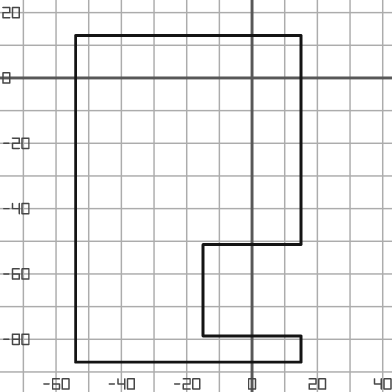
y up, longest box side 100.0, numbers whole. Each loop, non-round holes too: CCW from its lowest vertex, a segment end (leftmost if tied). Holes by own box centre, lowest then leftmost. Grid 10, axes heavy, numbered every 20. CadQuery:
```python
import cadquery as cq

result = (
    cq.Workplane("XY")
    .moveTo(-54.0, -87.0)
    .lineTo(15.0, -87.0)
    .lineTo(15.0, -79.0)
    .lineTo(-15.0, -79.0)
    .lineTo(-15.0, -51.0)
    .lineTo(15.0, -51.0)
    .lineTo(15.0, 13.0)
    .lineTo(-54.0, 13.0)
    .close()
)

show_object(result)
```